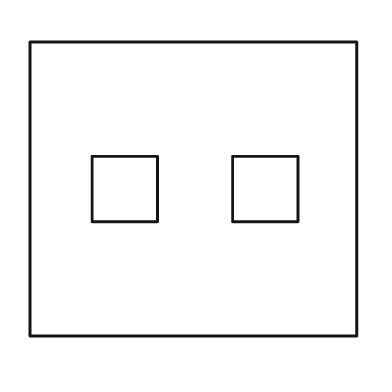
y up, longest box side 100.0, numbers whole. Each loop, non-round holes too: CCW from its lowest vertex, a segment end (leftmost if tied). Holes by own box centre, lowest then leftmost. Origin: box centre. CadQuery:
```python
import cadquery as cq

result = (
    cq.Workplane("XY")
    .moveTo(-50.0, -45.0)
    .lineTo(50.0, -45.0)
    .lineTo(50.0, 45.0)
    .lineTo(-50.0, 45.0)
    .close()
    .moveTo(-31.0, -10.0)
    .lineTo(-11.0, -10.0)
    .lineTo(-11.0, 10.0)
    .lineTo(-31.0, 10.0)
    .close()
    .moveTo(12.0, -10.0)
    .lineTo(32.0, -10.0)
    .lineTo(32.0, 10.0)
    .lineTo(12.0, 10.0)
    .close()
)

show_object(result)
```